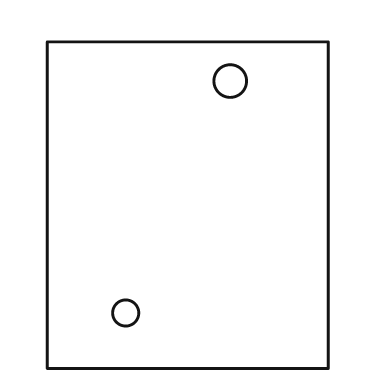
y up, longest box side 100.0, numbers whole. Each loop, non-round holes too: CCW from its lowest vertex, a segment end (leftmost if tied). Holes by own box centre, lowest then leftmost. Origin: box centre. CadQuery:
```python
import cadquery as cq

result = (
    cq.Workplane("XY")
    .moveTo(-43.0, -50.0)
    .lineTo(43.0, -50.0)
    .lineTo(43.0, 50.0)
    .lineTo(-43.0, 50.0)
    .close()
    .moveTo(-19.0, -33.0)
    .circle(4.0)
    .moveTo(13.0, 38.0)
    .circle(5.0)
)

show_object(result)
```